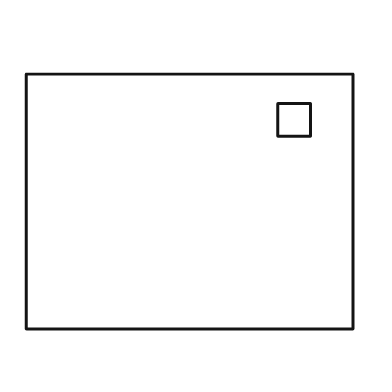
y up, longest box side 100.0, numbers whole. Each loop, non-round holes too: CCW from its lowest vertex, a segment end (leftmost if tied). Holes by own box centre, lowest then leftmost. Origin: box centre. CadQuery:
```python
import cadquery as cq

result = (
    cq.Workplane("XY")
    .moveTo(-50.0, -39.0)
    .lineTo(50.0, -39.0)
    .lineTo(50.0, 39.0)
    .lineTo(-50.0, 39.0)
    .close()
    .moveTo(27.0, 20.0)
    .lineTo(37.0, 20.0)
    .lineTo(37.0, 30.0)
    .lineTo(27.0, 30.0)
    .close()
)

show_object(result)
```